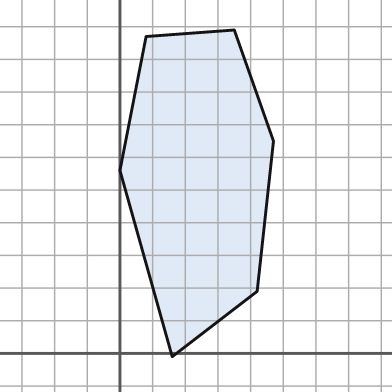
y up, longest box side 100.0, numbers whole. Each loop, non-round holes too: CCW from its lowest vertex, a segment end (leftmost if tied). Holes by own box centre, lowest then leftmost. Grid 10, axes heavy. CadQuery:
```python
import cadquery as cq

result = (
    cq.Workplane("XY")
    .moveTo(16.0, -1.0)
    .lineTo(42.0, 19.0)
    .lineTo(47.0, 65.0)
    .lineTo(35.0, 99.0)
    .lineTo(8.0, 97.0)
    .lineTo(0.0, 56.0)
    .close()
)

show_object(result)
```